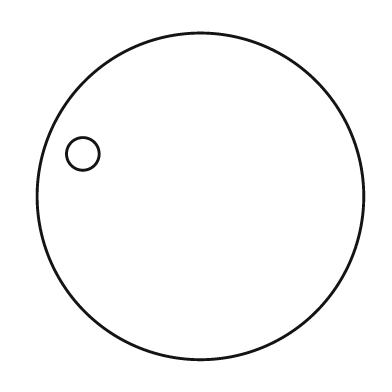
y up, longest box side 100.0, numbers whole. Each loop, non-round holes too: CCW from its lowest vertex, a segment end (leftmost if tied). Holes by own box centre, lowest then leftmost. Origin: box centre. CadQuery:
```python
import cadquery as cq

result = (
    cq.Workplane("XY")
    .moveTo(0.0, 0.0)
    .circle(50.0)
    .moveTo(-36.0, 13.0)
    .circle(5.0)
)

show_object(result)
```